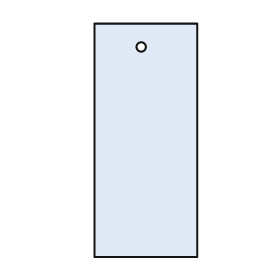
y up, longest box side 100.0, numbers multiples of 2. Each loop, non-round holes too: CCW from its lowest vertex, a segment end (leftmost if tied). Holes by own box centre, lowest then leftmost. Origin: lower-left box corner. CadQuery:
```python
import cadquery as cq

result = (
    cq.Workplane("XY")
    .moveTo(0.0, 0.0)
    .lineTo(44.0, 0.0)
    .lineTo(44.0, 100.0)
    .lineTo(0.0, 100.0)
    .close()
    .moveTo(20.0, 90.0)
    .circle(2.0)
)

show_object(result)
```